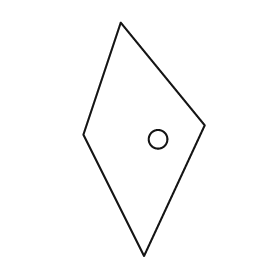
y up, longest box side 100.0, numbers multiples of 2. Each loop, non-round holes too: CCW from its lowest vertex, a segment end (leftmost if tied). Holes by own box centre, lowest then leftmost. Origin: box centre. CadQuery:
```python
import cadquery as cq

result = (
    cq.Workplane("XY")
    .moveTo(0.0, -50.0)
    .lineTo(26.0, 6.0)
    .lineTo(-10.0, 50.0)
    .lineTo(-26.0, 2.0)
    .close()
    .moveTo(6.0, 0.0)
    .circle(4.0)
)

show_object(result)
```